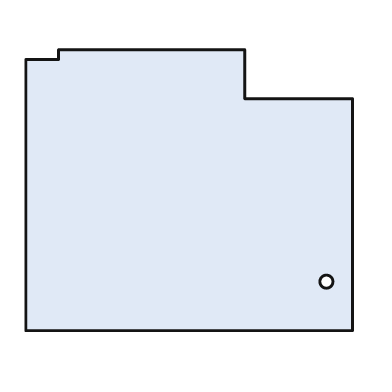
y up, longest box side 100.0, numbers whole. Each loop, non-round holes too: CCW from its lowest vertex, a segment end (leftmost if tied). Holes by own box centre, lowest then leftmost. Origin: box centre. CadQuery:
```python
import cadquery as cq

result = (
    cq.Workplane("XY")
    .moveTo(-50.0, -43.0)
    .lineTo(50.0, -43.0)
    .lineTo(50.0, 28.0)
    .lineTo(17.0, 28.0)
    .lineTo(17.0, 43.0)
    .lineTo(-40.0, 43.0)
    .lineTo(-40.0, 40.0)
    .lineTo(-50.0, 40.0)
    .close()
    .moveTo(42.0, -28.0)
    .circle(2.0)
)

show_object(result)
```